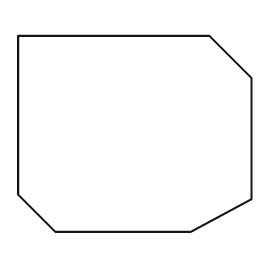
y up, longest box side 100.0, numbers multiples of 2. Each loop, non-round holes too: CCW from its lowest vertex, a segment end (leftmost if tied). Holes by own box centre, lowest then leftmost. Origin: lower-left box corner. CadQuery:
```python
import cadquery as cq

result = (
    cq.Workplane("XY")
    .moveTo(16.0, 0.0)
    .lineTo(74.0, 0.0)
    .lineTo(100.0, 14.0)
    .lineTo(100.0, 66.0)
    .lineTo(82.0, 84.0)
    .lineTo(0.0, 84.0)
    .lineTo(0.0, 16.0)
    .close()
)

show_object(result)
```